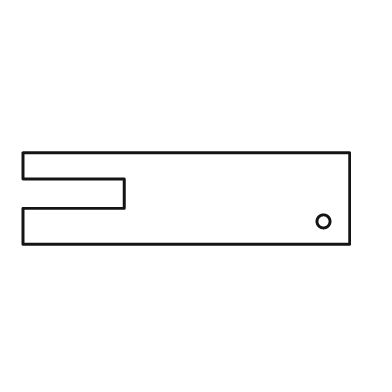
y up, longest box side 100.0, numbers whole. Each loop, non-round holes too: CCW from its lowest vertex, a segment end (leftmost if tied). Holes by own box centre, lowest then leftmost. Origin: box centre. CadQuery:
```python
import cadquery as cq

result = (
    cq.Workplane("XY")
    .moveTo(-50.0, -14.0)
    .lineTo(50.0, -14.0)
    .lineTo(50.0, 14.0)
    .lineTo(-50.0, 14.0)
    .lineTo(-50.0, 6.0)
    .lineTo(-19.0, 6.0)
    .lineTo(-19.0, -3.0)
    .lineTo(-50.0, -3.0)
    .close()
    .moveTo(42.0, -7.0)
    .circle(2.0)
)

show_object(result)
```